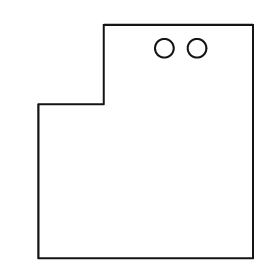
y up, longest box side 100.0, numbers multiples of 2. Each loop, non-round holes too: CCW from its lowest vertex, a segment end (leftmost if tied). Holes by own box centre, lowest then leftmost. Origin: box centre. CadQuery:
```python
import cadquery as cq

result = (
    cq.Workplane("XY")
    .moveTo(-46.0, -50.0)
    .lineTo(46.0, -50.0)
    .lineTo(46.0, 50.0)
    .lineTo(-18.0, 50.0)
    .lineTo(-18.0, 16.0)
    .lineTo(-46.0, 16.0)
    .close()
    .moveTo(8.0, 40.0)
    .circle(4.0)
    .moveTo(22.0, 40.0)
    .circle(4.0)
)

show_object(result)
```